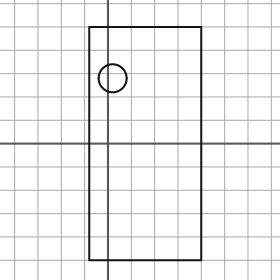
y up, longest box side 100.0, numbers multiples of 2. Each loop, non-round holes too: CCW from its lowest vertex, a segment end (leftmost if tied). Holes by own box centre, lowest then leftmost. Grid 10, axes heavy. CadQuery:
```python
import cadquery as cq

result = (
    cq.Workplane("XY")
    .moveTo(-8.0, -50.0)
    .lineTo(40.0, -50.0)
    .lineTo(40.0, 50.0)
    .lineTo(-8.0, 50.0)
    .close()
    .moveTo(2.0, 28.0)
    .circle(6.0)
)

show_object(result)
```